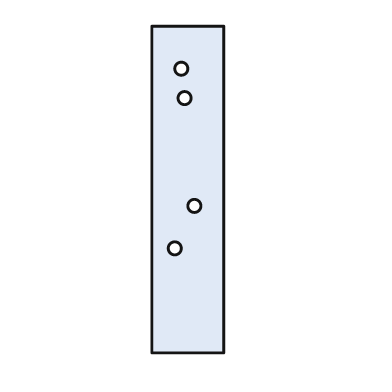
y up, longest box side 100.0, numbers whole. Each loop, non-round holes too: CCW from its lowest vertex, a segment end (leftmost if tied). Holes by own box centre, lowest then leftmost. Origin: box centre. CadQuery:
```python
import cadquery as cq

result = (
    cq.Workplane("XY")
    .moveTo(-11.0, -50.0)
    .lineTo(11.0, -50.0)
    .lineTo(11.0, 50.0)
    .lineTo(-11.0, 50.0)
    .close()
    .moveTo(-4.0, -18.0)
    .circle(2.0)
    .moveTo(2.0, -5.0)
    .circle(2.0)
    .moveTo(-1.0, 28.0)
    .circle(2.0)
    .moveTo(-2.0, 37.0)
    .circle(2.0)
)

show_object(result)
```